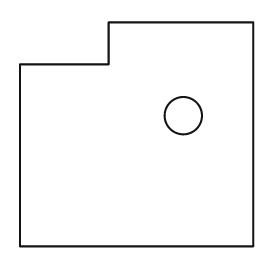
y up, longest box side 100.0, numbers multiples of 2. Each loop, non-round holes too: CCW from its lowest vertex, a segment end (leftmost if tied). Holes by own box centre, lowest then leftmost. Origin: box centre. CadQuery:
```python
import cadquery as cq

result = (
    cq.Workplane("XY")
    .moveTo(-50.0, -48.0)
    .lineTo(50.0, -48.0)
    .lineTo(50.0, 48.0)
    .lineTo(-12.0, 48.0)
    .lineTo(-12.0, 30.0)
    .lineTo(-50.0, 30.0)
    .close()
    .moveTo(20.0, 8.0)
    .circle(8.0)
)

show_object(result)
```